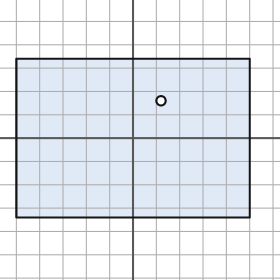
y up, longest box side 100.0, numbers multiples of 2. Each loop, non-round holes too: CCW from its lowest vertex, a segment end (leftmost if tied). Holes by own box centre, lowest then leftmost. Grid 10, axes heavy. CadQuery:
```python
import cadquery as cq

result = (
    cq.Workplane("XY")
    .moveTo(-50.0, -34.0)
    .lineTo(50.0, -34.0)
    .lineTo(50.0, 34.0)
    .lineTo(-50.0, 34.0)
    .close()
    .moveTo(12.0, 16.0)
    .circle(2.0)
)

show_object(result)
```